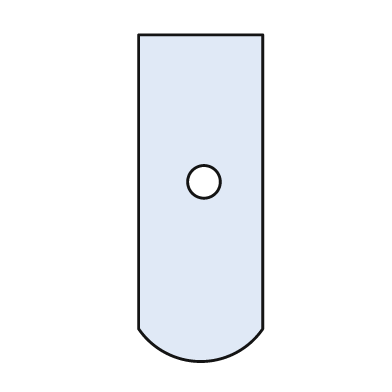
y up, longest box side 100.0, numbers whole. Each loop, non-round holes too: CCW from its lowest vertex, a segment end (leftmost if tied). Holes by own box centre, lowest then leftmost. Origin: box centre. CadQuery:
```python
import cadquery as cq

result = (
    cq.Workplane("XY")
    .moveTo(-19.0, -40.0)
    .threePointArc((0.0, -50.0), (19.0, -40.0))
    .lineTo(19.0, 50.0)
    .lineTo(-19.0, 50.0)
    .close()
    .moveTo(1.0, 5.0)
    .circle(5.0)
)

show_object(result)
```